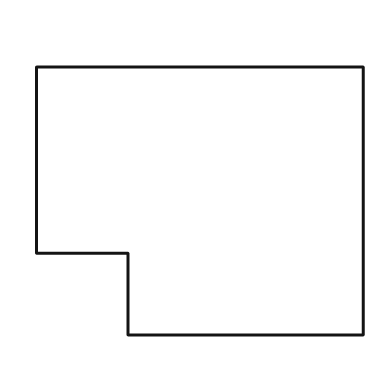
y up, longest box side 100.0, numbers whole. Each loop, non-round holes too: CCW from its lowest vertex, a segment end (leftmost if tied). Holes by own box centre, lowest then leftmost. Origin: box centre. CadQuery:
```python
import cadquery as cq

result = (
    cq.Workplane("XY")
    .moveTo(-22.0, -41.0)
    .lineTo(50.0, -41.0)
    .lineTo(50.0, 41.0)
    .lineTo(-50.0, 41.0)
    .lineTo(-50.0, -16.0)
    .lineTo(-22.0, -16.0)
    .close()
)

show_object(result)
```